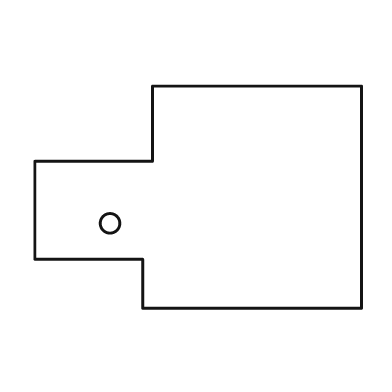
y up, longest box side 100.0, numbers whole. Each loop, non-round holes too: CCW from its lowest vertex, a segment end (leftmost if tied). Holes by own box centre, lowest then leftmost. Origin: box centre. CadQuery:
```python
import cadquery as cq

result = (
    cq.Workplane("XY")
    .moveTo(-17.0, -34.0)
    .lineTo(50.0, -34.0)
    .lineTo(50.0, 34.0)
    .lineTo(-14.0, 34.0)
    .lineTo(-14.0, 11.0)
    .lineTo(-50.0, 11.0)
    .lineTo(-50.0, -19.0)
    .lineTo(-17.0, -19.0)
    .close()
    .moveTo(-27.0, -8.0)
    .circle(3.0)
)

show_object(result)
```